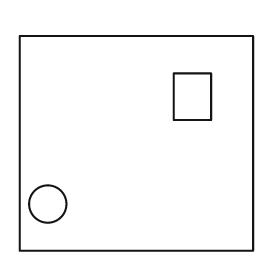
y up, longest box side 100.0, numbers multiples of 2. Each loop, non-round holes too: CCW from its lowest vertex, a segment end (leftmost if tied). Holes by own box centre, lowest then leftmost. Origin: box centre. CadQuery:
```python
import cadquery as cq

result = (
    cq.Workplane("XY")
    .moveTo(-50.0, -46.0)
    .lineTo(50.0, -46.0)
    .lineTo(50.0, 46.0)
    .lineTo(-50.0, 46.0)
    .close()
    .moveTo(-38.0, -26.0)
    .circle(8.0)
    .moveTo(16.0, 10.0)
    .lineTo(32.0, 10.0)
    .lineTo(32.0, 30.0)
    .lineTo(16.0, 30.0)
    .close()
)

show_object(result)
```